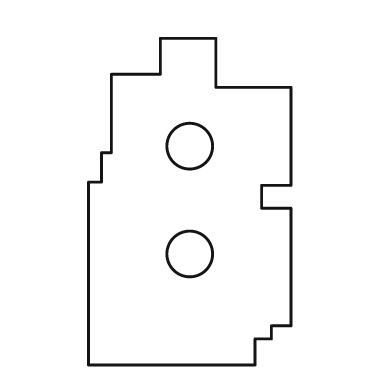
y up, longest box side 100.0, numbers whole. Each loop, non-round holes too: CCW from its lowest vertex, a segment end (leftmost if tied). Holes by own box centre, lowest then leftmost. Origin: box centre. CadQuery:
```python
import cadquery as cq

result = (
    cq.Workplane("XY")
    .moveTo(-31.0, -50.0)
    .lineTo(20.0, -50.0)
    .lineTo(20.0, -42.0)
    .lineTo(25.0, -42.0)
    .lineTo(25.0, -38.0)
    .lineTo(31.0, -38.0)
    .lineTo(31.0, -2.0)
    .lineTo(22.0, -2.0)
    .lineTo(22.0, 5.0)
    .lineTo(31.0, 5.0)
    .lineTo(31.0, 35.0)
    .lineTo(8.0, 35.0)
    .lineTo(8.0, 50.0)
    .lineTo(-9.0, 50.0)
    .lineTo(-9.0, 39.0)
    .lineTo(-24.0, 39.0)
    .lineTo(-24.0, 15.0)
    .lineTo(-27.0, 15.0)
    .lineTo(-27.0, 6.0)
    .lineTo(-31.0, 6.0)
    .close()
    .moveTo(0.0, -16.0)
    .circle(7.0)
    .moveTo(0.0, 17.0)
    .circle(7.0)
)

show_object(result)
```